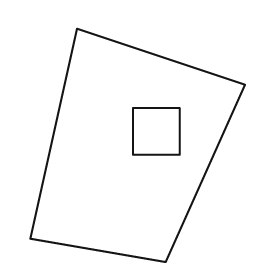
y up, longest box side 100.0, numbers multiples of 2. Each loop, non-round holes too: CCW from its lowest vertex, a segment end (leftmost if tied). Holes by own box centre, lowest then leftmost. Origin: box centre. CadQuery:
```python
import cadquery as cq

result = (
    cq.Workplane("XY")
    .moveTo(12.0, -50.0)
    .lineTo(46.0, 26.0)
    .lineTo(-26.0, 50.0)
    .lineTo(-46.0, -40.0)
    .close()
    .moveTo(-2.0, -4.0)
    .lineTo(18.0, -4.0)
    .lineTo(18.0, 16.0)
    .lineTo(-2.0, 16.0)
    .close()
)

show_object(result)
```